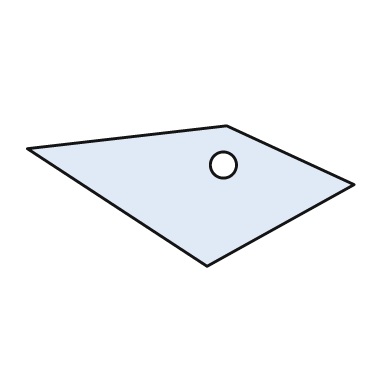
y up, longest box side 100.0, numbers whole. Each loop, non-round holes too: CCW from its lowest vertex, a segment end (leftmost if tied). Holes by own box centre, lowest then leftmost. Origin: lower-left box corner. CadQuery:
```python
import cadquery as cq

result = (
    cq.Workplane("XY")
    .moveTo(55.0, 0.0)
    .lineTo(100.0, 25.0)
    .lineTo(61.0, 43.0)
    .lineTo(0.0, 36.0)
    .close()
    .moveTo(60.0, 31.0)
    .circle(4.0)
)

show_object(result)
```